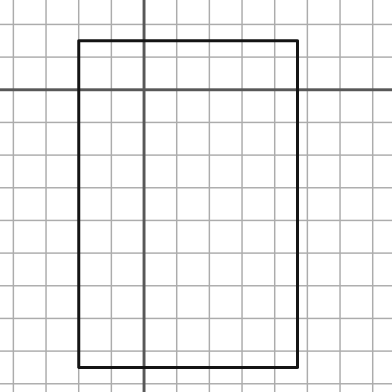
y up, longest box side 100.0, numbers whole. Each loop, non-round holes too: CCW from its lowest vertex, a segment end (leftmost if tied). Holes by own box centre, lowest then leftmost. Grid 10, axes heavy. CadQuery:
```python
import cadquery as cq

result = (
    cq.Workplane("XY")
    .moveTo(-20.0, -85.0)
    .lineTo(47.0, -85.0)
    .lineTo(47.0, 15.0)
    .lineTo(-20.0, 15.0)
    .close()
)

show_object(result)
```